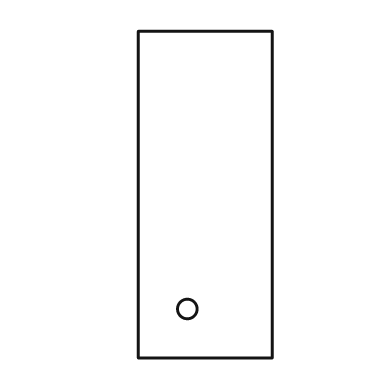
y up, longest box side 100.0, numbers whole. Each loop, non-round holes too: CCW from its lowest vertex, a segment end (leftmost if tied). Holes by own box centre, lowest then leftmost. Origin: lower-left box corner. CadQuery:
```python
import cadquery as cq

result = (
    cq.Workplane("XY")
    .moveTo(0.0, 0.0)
    .lineTo(41.0, 0.0)
    .lineTo(41.0, 100.0)
    .lineTo(0.0, 100.0)
    .close()
    .moveTo(15.0, 15.0)
    .circle(3.0)
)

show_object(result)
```